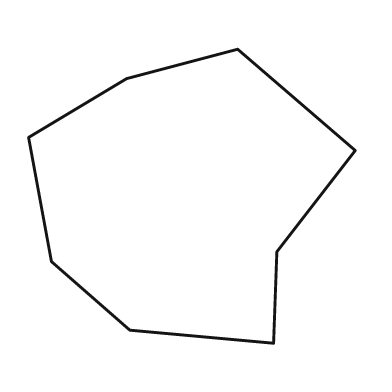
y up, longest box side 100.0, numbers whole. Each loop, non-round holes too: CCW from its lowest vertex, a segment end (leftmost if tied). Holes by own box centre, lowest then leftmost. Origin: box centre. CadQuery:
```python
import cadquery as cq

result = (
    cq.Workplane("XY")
    .moveTo(25.0, -45.0)
    .lineTo(26.0, -17.0)
    .lineTo(50.0, 14.0)
    .lineTo(14.0, 45.0)
    .lineTo(-20.0, 36.0)
    .lineTo(-50.0, 18.0)
    .lineTo(-43.0, -20.0)
    .lineTo(-19.0, -41.0)
    .close()
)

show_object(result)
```